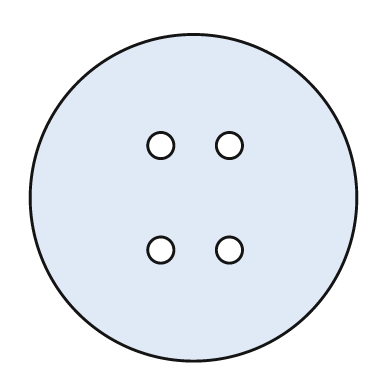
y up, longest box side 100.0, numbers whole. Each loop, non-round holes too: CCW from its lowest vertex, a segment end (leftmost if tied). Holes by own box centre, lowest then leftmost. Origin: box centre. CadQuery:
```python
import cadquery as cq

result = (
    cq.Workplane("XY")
    .moveTo(0.0, 0.0)
    .circle(50.0)
    .moveTo(-10.0, -16.0)
    .circle(4.0)
    .moveTo(11.0, -16.0)
    .circle(4.0)
    .moveTo(-10.0, 16.0)
    .circle(4.0)
    .moveTo(11.0, 16.0)
    .circle(4.0)
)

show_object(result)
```